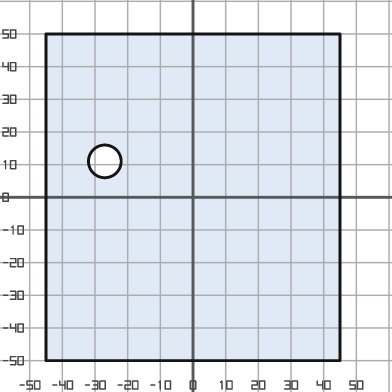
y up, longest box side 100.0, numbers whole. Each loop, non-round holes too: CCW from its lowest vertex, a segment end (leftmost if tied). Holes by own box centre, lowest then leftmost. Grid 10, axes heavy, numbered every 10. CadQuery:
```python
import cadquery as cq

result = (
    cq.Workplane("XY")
    .moveTo(-45.0, -50.0)
    .lineTo(45.0, -50.0)
    .lineTo(45.0, 50.0)
    .lineTo(-45.0, 50.0)
    .close()
    .moveTo(-27.0, 11.0)
    .circle(5.0)
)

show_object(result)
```